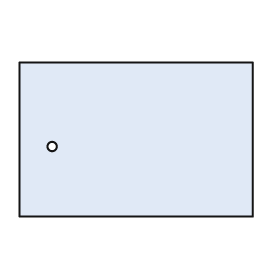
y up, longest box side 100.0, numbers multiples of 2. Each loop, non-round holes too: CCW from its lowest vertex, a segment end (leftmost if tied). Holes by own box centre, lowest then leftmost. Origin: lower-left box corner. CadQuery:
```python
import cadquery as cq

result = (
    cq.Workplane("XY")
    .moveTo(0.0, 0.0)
    .lineTo(100.0, 0.0)
    .lineTo(100.0, 66.0)
    .lineTo(0.0, 66.0)
    .close()
    .moveTo(14.0, 30.0)
    .circle(2.0)
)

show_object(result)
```